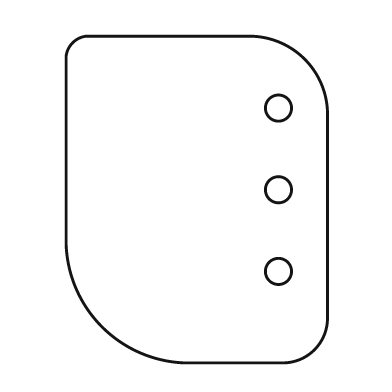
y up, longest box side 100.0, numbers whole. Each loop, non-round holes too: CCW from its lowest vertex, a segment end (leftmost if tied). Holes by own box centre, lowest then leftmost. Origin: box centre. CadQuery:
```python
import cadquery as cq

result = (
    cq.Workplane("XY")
    .moveTo(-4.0, -50.0)
    .lineTo(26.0, -50.0)
    .threePointArc((36.0, -46.0), (40.0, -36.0))
    .lineTo(40.0, 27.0)
    .threePointArc((33.0, 43.0), (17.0, 50.0))
    .lineTo(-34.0, 50.0)
    .threePointArc((-38.0, 48.0), (-40.0, 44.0))
    .lineTo(-40.0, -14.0)
    .threePointArc((-29.0, -39.0), (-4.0, -50.0))
    .close()
    .moveTo(25.0, -22.0)
    .circle(4.0)
    .moveTo(25.0, 3.0)
    .circle(4.0)
    .moveTo(25.0, 28.0)
    .circle(4.0)
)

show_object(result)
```